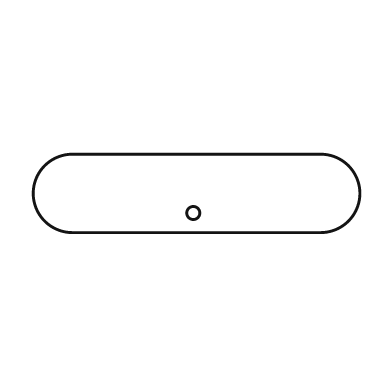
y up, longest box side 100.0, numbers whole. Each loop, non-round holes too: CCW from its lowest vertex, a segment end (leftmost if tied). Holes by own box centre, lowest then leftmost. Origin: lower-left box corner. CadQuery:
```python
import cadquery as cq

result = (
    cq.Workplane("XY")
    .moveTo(12.0, 0.0)
    .lineTo(88.0, 0.0)
    .threePointArc((100.0, 12.0), (88.0, 24.0))
    .lineTo(12.0, 24.0)
    .threePointArc((0.0, 12.0), (12.0, 0.0))
    .close()
    .moveTo(49.0, 6.0)
    .circle(2.0)
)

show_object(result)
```